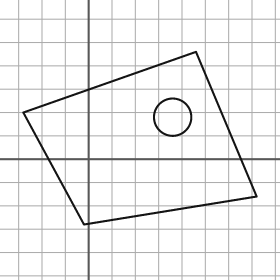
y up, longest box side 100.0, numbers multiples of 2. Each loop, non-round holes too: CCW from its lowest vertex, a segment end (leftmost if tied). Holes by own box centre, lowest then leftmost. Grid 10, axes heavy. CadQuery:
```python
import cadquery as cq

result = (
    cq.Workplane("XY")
    .moveTo(-2.0, -28.0)
    .lineTo(72.0, -16.0)
    .lineTo(46.0, 46.0)
    .lineTo(-28.0, 20.0)
    .close()
    .moveTo(36.0, 18.0)
    .circle(8.0)
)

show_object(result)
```